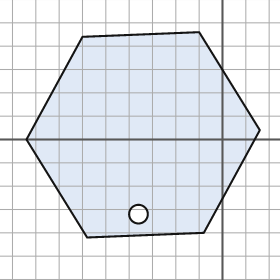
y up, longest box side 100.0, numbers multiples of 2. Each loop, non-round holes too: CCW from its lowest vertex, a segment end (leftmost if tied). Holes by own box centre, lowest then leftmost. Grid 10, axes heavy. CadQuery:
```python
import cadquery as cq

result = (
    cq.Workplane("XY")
    .moveTo(-58.0, -42.0)
    .lineTo(-8.0, -40.0)
    .lineTo(16.0, 4.0)
    .lineTo(-10.0, 46.0)
    .lineTo(-60.0, 44.0)
    .lineTo(-84.0, 0.0)
    .close()
    .moveTo(-36.0, -32.0)
    .circle(4.0)
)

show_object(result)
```